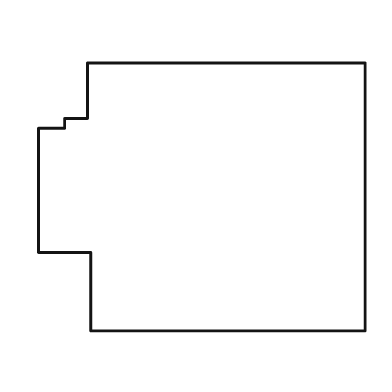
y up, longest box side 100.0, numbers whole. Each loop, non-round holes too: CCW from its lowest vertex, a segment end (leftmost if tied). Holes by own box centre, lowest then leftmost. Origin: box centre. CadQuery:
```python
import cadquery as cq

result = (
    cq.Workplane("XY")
    .moveTo(-34.0, -41.0)
    .lineTo(50.0, -41.0)
    .lineTo(50.0, 41.0)
    .lineTo(-35.0, 41.0)
    .lineTo(-35.0, 24.0)
    .lineTo(-42.0, 24.0)
    .lineTo(-42.0, 21.0)
    .lineTo(-50.0, 21.0)
    .lineTo(-50.0, -17.0)
    .lineTo(-34.0, -17.0)
    .close()
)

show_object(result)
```